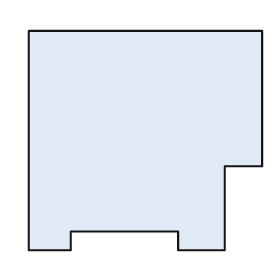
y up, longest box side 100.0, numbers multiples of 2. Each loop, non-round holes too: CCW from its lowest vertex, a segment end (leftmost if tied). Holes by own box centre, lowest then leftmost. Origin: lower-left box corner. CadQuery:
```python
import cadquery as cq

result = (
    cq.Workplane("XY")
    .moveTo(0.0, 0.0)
    .lineTo(18.0, 0.0)
    .lineTo(18.0, 8.0)
    .lineTo(64.0, 8.0)
    .lineTo(64.0, 0.0)
    .lineTo(84.0, 0.0)
    .lineTo(84.0, 36.0)
    .lineTo(100.0, 36.0)
    .lineTo(100.0, 94.0)
    .lineTo(0.0, 94.0)
    .close()
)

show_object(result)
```